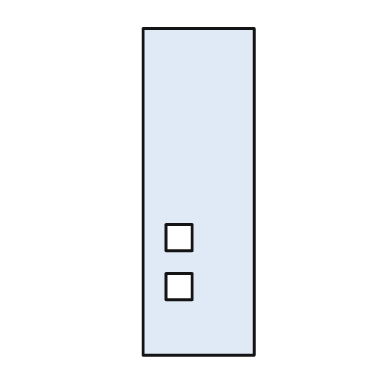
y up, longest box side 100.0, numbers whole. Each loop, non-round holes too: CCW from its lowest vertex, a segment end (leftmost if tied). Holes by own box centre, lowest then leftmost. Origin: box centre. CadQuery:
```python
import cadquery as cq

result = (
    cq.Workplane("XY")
    .moveTo(-17.0, -50.0)
    .lineTo(17.0, -50.0)
    .lineTo(17.0, 50.0)
    .lineTo(-17.0, 50.0)
    .close()
    .moveTo(-10.0, -33.0)
    .lineTo(-2.0, -33.0)
    .lineTo(-2.0, -25.0)
    .lineTo(-10.0, -25.0)
    .close()
    .moveTo(-10.0, -18.0)
    .lineTo(-2.0, -18.0)
    .lineTo(-2.0, -10.0)
    .lineTo(-10.0, -10.0)
    .close()
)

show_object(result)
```